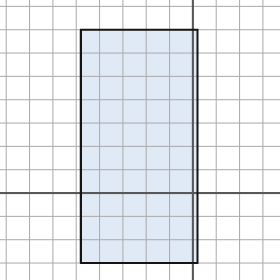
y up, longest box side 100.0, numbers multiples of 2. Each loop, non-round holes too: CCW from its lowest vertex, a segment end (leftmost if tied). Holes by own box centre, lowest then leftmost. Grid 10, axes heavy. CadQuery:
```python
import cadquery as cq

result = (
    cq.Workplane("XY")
    .moveTo(-48.0, -30.0)
    .lineTo(2.0, -30.0)
    .lineTo(2.0, 70.0)
    .lineTo(-48.0, 70.0)
    .close()
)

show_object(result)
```